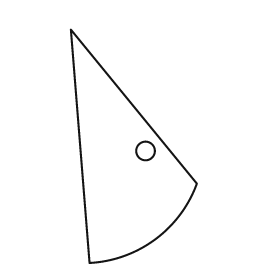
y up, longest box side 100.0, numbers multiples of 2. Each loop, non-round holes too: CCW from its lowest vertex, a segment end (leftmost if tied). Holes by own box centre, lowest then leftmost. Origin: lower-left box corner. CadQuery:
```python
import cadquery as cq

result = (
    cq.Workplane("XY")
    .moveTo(8.0, 0.0)
    .threePointArc((36.0, 10.0), (54.0, 34.0))
    .lineTo(0.0, 100.0)
    .close()
    .moveTo(32.0, 48.0)
    .circle(4.0)
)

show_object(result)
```